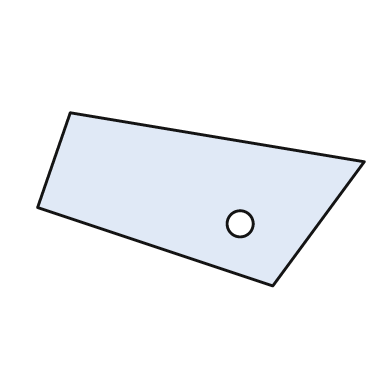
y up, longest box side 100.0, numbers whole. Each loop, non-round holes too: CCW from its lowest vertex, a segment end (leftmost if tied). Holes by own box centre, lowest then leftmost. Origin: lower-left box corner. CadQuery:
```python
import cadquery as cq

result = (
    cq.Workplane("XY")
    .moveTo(72.0, 0.0)
    .lineTo(100.0, 38.0)
    .lineTo(10.0, 53.0)
    .lineTo(0.0, 24.0)
    .close()
    .moveTo(62.0, 19.0)
    .circle(4.0)
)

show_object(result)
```